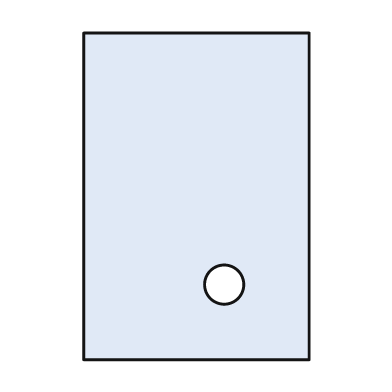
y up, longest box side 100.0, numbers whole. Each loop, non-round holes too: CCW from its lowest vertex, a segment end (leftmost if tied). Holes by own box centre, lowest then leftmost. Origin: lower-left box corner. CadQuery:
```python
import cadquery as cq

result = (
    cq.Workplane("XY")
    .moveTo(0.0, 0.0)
    .lineTo(69.0, 0.0)
    .lineTo(69.0, 100.0)
    .lineTo(0.0, 100.0)
    .close()
    .moveTo(43.0, 23.0)
    .circle(6.0)
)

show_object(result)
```